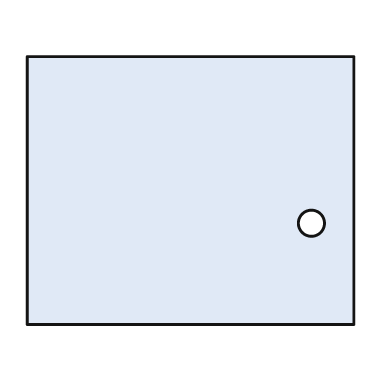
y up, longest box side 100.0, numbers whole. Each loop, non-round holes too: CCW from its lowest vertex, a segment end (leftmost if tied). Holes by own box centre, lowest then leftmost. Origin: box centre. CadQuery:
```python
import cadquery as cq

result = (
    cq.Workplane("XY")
    .moveTo(-50.0, -41.0)
    .lineTo(50.0, -41.0)
    .lineTo(50.0, 41.0)
    .lineTo(-50.0, 41.0)
    .close()
    .moveTo(37.0, -10.0)
    .circle(4.0)
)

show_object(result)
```